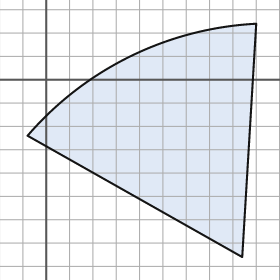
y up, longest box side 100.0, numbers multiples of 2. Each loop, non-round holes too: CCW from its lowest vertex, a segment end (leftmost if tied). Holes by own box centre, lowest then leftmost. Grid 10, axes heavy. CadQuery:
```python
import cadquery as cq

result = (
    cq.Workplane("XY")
    .moveTo(84.0, -76.0)
    .lineTo(90.0, 24.0)
    .threePointArc((36.0, 10.0), (-8.0, -24.0))
    .close()
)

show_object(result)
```